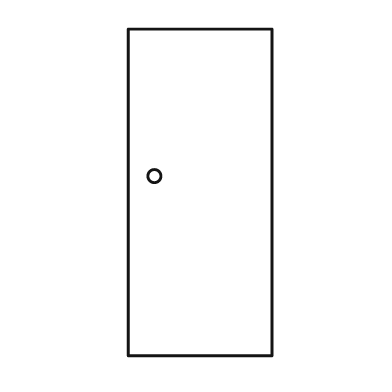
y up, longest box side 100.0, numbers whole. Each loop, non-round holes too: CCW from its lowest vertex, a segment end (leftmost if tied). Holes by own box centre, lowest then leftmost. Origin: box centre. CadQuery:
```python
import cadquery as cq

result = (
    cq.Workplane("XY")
    .moveTo(-22.0, -50.0)
    .lineTo(22.0, -50.0)
    .lineTo(22.0, 50.0)
    .lineTo(-22.0, 50.0)
    .close()
    .moveTo(-14.0, 5.0)
    .circle(2.0)
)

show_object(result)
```